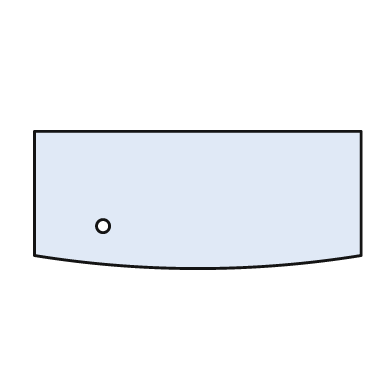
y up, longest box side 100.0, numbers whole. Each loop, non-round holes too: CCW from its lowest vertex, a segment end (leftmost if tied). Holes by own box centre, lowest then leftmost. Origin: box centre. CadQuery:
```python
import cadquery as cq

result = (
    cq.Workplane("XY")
    .moveTo(-50.0, -17.0)
    .threePointArc((0.0, -21.0), (50.0, -17.0))
    .lineTo(50.0, 21.0)
    .lineTo(-50.0, 21.0)
    .close()
    .moveTo(-29.0, -8.0)
    .circle(2.0)
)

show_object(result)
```